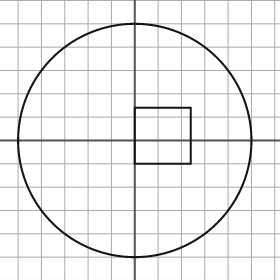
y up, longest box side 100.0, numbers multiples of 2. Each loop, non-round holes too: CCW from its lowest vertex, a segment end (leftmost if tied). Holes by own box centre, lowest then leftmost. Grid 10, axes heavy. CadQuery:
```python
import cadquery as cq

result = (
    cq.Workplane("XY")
    .moveTo(0.0, 0.0)
    .circle(50.0)
    .moveTo(0.0, -10.0)
    .lineTo(24.0, -10.0)
    .lineTo(24.0, 14.0)
    .lineTo(0.0, 14.0)
    .close()
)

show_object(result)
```